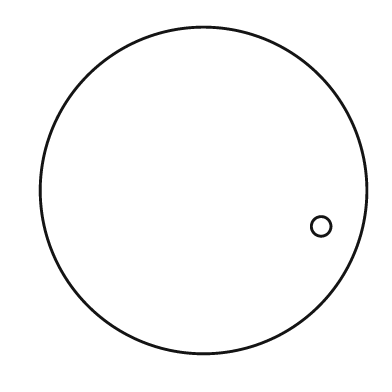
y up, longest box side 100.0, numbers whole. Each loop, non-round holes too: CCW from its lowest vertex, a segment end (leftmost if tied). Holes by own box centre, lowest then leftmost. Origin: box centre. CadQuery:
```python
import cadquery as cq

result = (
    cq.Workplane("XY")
    .moveTo(0.0, 0.0)
    .circle(50.0)
    .moveTo(36.0, -11.0)
    .circle(3.0)
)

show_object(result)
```